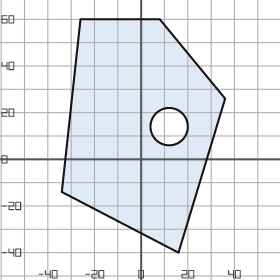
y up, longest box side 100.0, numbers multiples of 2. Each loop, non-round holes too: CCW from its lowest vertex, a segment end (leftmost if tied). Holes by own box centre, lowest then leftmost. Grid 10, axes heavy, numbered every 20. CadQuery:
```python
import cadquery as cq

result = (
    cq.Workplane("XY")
    .moveTo(16.0, -40.0)
    .lineTo(36.0, 26.0)
    .lineTo(8.0, 60.0)
    .lineTo(-26.0, 60.0)
    .lineTo(-34.0, -14.0)
    .close()
    .moveTo(12.0, 14.0)
    .circle(8.0)
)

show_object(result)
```